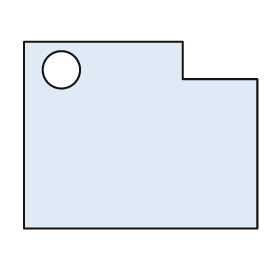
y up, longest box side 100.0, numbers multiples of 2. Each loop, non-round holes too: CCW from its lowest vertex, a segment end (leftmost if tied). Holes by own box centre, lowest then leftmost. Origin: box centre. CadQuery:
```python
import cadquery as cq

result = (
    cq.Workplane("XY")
    .moveTo(-50.0, -40.0)
    .lineTo(50.0, -40.0)
    .lineTo(50.0, 24.0)
    .lineTo(18.0, 24.0)
    .lineTo(18.0, 40.0)
    .lineTo(-50.0, 40.0)
    .close()
    .moveTo(-34.0, 28.0)
    .circle(8.0)
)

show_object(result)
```